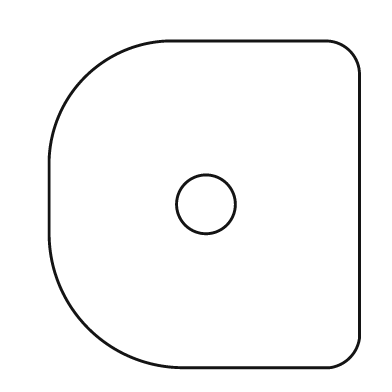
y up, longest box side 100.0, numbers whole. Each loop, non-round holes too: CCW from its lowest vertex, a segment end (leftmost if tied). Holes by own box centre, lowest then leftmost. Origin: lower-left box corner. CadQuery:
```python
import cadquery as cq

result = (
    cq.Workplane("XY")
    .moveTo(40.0, 0.0)
    .lineTo(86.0, 0.0)
    .threePointArc((92.0, 3.0), (95.0, 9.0))
    .lineTo(95.0, 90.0)
    .threePointArc((92.0, 97.0), (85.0, 100.0))
    .lineTo(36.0, 100.0)
    .threePointArc((11.0, 89.0), (0.0, 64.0))
    .lineTo(0.0, 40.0)
    .threePointArc((12.0, 12.0), (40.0, 0.0))
    .close()
    .moveTo(48.0, 50.0)
    .circle(9.0)
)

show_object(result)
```